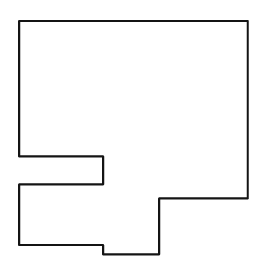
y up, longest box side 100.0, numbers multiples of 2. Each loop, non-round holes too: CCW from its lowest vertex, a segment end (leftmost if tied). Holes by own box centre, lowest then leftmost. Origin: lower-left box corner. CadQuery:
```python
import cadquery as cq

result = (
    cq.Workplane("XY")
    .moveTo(36.0, 0.0)
    .lineTo(60.0, 0.0)
    .lineTo(60.0, 24.0)
    .lineTo(98.0, 24.0)
    .lineTo(98.0, 100.0)
    .lineTo(0.0, 100.0)
    .lineTo(0.0, 42.0)
    .lineTo(36.0, 42.0)
    .lineTo(36.0, 30.0)
    .lineTo(0.0, 30.0)
    .lineTo(0.0, 4.0)
    .lineTo(36.0, 4.0)
    .close()
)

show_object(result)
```